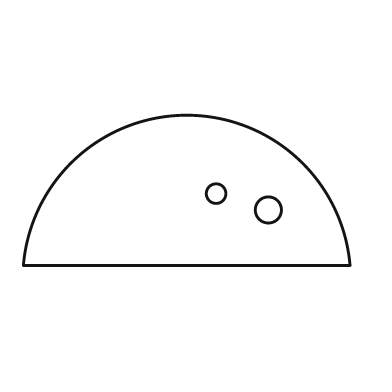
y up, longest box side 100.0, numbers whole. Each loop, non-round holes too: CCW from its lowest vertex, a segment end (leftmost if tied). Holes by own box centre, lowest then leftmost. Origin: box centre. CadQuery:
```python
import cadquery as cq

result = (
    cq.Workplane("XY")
    .moveTo(-50.0, -23.0)
    .lineTo(50.0, -23.0)
    .threePointArc((0.0, 23.0), (-50.0, -23.0))
    .close()
    .moveTo(25.0, -6.0)
    .circle(4.0)
    .moveTo(9.0, -1.0)
    .circle(3.0)
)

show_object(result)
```